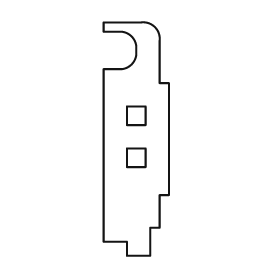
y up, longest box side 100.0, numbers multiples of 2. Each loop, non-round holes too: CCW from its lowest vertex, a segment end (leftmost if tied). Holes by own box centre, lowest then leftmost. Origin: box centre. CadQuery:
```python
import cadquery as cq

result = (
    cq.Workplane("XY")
    .moveTo(-4.0, -50.0)
    .lineTo(6.0, -50.0)
    .lineTo(6.0, -38.0)
    .lineTo(10.0, -38.0)
    .lineTo(10.0, -24.0)
    .lineTo(14.0, -24.0)
    .lineTo(14.0, 24.0)
    .lineTo(10.0, 24.0)
    .lineTo(10.0, 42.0)
    .threePointArc((8.0, 48.0), (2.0, 50.0))
    .lineTo(-14.0, 50.0)
    .lineTo(-14.0, 46.0)
    .lineTo(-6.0, 46.0)
    .threePointArc((-2.0, 44.0), (0.0, 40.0))
    .lineTo(0.0, 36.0)
    .threePointArc((-2.0, 32.0), (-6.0, 30.0))
    .lineTo(-14.0, 30.0)
    .lineTo(-14.0, -44.0)
    .lineTo(-4.0, -44.0)
    .close()
    .moveTo(-4.0, -12.0)
    .lineTo(4.0, -12.0)
    .lineTo(4.0, -4.0)
    .lineTo(-4.0, -4.0)
    .close()
    .moveTo(-4.0, 6.0)
    .lineTo(4.0, 6.0)
    .lineTo(4.0, 14.0)
    .lineTo(-4.0, 14.0)
    .close()
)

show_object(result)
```